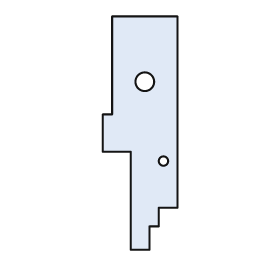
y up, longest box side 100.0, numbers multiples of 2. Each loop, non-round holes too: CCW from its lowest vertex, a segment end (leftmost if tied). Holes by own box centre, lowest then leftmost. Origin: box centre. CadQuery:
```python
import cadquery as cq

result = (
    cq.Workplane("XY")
    .moveTo(-4.0, -50.0)
    .lineTo(4.0, -50.0)
    .lineTo(4.0, -40.0)
    .lineTo(8.0, -40.0)
    .lineTo(8.0, -32.0)
    .lineTo(16.0, -32.0)
    .lineTo(16.0, 50.0)
    .lineTo(-12.0, 50.0)
    .lineTo(-12.0, 8.0)
    .lineTo(-16.0, 8.0)
    .lineTo(-16.0, -8.0)
    .lineTo(-4.0, -8.0)
    .close()
    .moveTo(10.0, -12.0)
    .circle(2.0)
    .moveTo(2.0, 22.0)
    .circle(4.0)
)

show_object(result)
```